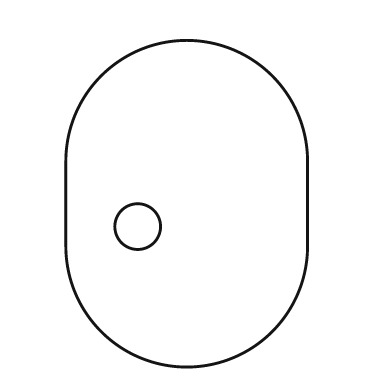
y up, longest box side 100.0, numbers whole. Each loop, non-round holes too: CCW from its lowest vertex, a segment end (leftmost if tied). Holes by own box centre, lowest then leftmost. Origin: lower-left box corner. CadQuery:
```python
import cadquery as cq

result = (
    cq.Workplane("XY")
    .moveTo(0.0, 37.0)
    .threePointArc((37.0, 0.0), (74.0, 37.0))
    .lineTo(74.0, 63.0)
    .threePointArc((37.0, 100.0), (0.0, 63.0))
    .close()
    .moveTo(22.0, 43.0)
    .circle(7.0)
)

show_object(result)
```